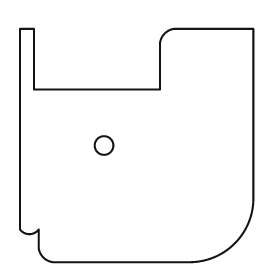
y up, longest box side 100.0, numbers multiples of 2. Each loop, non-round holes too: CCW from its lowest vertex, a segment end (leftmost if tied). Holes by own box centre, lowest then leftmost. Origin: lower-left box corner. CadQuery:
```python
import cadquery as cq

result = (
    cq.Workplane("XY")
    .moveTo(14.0, 0.0)
    .lineTo(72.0, 0.0)
    .threePointArc((92.0, 8.0), (100.0, 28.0))
    .lineTo(100.0, 100.0)
    .lineTo(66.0, 100.0)
    .threePointArc((62.0, 98.0), (60.0, 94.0))
    .lineTo(60.0, 74.0)
    .lineTo(6.0, 74.0)
    .lineTo(6.0, 100.0)
    .lineTo(0.0, 100.0)
    .lineTo(0.0, 14.0)
    .threePointArc((4.0, 12.0), (8.0, 14.0))
    .lineTo(8.0, 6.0)
    .threePointArc((10.0, 2.0), (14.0, 0.0))
    .close()
    .moveTo(36.0, 50.0)
    .circle(4.0)
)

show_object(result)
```